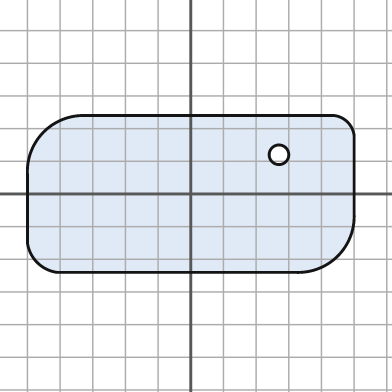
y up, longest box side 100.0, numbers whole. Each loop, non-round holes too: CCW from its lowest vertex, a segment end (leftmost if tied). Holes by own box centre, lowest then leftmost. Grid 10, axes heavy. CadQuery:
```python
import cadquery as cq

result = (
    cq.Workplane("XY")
    .moveTo(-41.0, -24.0)
    .lineTo(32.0, -24.0)
    .threePointArc((45.0, -19.0), (50.0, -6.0))
    .lineTo(50.0, 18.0)
    .threePointArc((48.0, 22.0), (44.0, 24.0))
    .lineTo(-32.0, 24.0)
    .threePointArc((-45.0, 19.0), (-50.0, 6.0))
    .lineTo(-50.0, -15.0)
    .threePointArc((-47.0, -21.0), (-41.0, -24.0))
    .close()
    .moveTo(27.0, 12.0)
    .circle(3.0)
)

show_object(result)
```